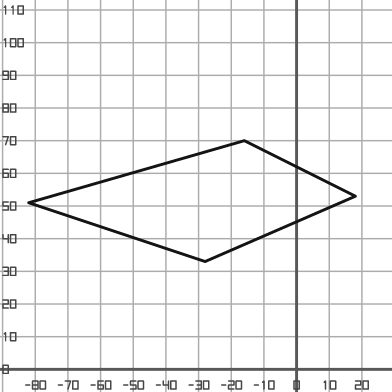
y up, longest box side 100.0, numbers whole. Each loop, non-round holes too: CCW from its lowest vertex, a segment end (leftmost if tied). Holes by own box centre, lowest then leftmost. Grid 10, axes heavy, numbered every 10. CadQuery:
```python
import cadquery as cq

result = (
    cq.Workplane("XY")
    .moveTo(-28.0, 33.0)
    .lineTo(18.0, 53.0)
    .lineTo(-16.0, 70.0)
    .lineTo(-82.0, 51.0)
    .close()
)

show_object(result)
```